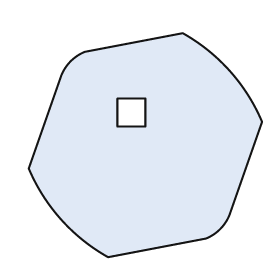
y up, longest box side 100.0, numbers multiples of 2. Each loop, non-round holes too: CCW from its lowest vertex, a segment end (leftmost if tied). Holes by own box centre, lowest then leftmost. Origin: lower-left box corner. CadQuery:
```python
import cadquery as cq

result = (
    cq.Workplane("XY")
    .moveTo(34.0, 0.0)
    .lineTo(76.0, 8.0)
    .threePointArc((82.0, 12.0), (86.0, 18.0))
    .lineTo(100.0, 58.0)
    .threePointArc((86.0, 80.0), (66.0, 96.0))
    .lineTo(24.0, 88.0)
    .threePointArc((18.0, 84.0), (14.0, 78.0))
    .lineTo(0.0, 38.0)
    .threePointArc((14.0, 16.0), (34.0, 0.0))
    .close()
    .moveTo(38.0, 56.0)
    .lineTo(50.0, 56.0)
    .lineTo(50.0, 68.0)
    .lineTo(38.0, 68.0)
    .close()
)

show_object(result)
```